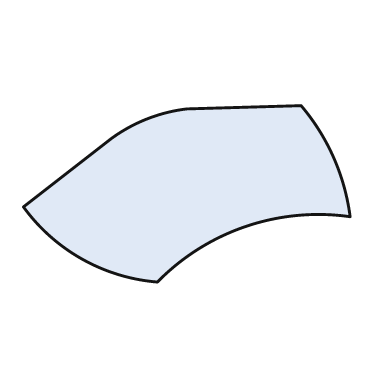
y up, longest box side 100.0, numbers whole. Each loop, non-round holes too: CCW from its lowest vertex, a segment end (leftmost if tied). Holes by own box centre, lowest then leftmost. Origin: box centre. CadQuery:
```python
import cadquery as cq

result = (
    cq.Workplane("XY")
    .moveTo(-9.0, -27.0)
    .threePointArc((18.0, -10.0), (50.0, -7.0))
    .threePointArc((45.0, 11.0), (35.0, 27.0))
    .lineTo(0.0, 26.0)
    .threePointArc((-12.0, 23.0), (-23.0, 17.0))
    .lineTo(-50.0, -4.0)
    .threePointArc((-32.0, -20.0), (-9.0, -27.0))
    .close()
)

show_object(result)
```